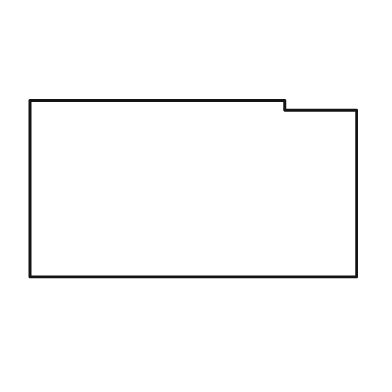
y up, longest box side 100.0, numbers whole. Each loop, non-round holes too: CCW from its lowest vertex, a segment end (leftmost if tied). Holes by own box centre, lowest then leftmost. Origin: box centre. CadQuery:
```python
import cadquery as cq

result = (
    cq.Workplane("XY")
    .moveTo(-50.0, -27.0)
    .lineTo(50.0, -27.0)
    .lineTo(50.0, 24.0)
    .lineTo(28.0, 24.0)
    .lineTo(28.0, 27.0)
    .lineTo(-50.0, 27.0)
    .close()
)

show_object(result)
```